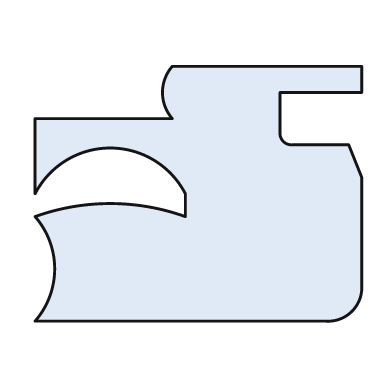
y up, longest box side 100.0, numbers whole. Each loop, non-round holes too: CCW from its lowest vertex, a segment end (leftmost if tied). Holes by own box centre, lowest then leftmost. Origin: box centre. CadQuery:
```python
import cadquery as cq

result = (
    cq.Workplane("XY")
    .moveTo(-50.0, -39.0)
    .lineTo(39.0, -39.0)
    .threePointArc((47.0, -36.0), (50.0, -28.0))
    .lineTo(50.0, 5.0)
    .lineTo(46.0, 15.0)
    .lineTo(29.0, 15.0)
    .threePointArc((26.0, 16.0), (25.0, 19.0))
    .lineTo(25.0, 31.0)
    .lineTo(50.0, 31.0)
    .lineTo(50.0, 39.0)
    .lineTo(-8.0, 39.0)
    .threePointArc((-11.0, 31.0), (-8.0, 23.0))
    .lineTo(-50.0, 23.0)
    .lineTo(-50.0, 0.0)
    .threePointArc((-27.0, 14.0), (-4.0, 0.0))
    .lineTo(-4.0, -7.0)
    .threePointArc((-27.0, -3.0), (-50.0, -7.0))
    .threePointArc((-44.0, -23.0), (-50.0, -39.0))
    .close()
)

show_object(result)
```